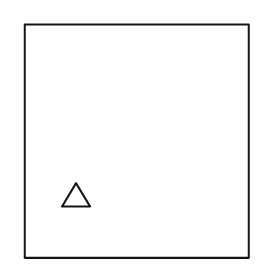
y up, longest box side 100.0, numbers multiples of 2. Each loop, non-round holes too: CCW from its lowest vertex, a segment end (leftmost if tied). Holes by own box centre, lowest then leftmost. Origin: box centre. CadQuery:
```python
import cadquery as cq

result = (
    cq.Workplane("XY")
    .moveTo(-48.0, -50.0)
    .lineTo(48.0, -50.0)
    .lineTo(48.0, 50.0)
    .lineTo(-48.0, 50.0)
    .close()
    .moveTo(-32.0, -28.0)
    .lineTo(-20.0, -28.0)
    .lineTo(-26.0, -18.0)
    .close()
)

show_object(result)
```